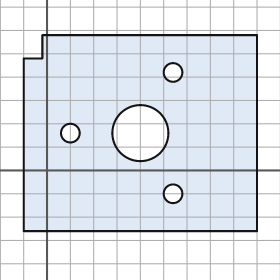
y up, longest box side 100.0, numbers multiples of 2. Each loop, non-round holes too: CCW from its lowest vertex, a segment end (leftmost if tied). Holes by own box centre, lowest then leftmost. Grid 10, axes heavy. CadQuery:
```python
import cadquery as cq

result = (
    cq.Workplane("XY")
    .moveTo(-10.0, -26.0)
    .lineTo(90.0, -26.0)
    .lineTo(90.0, 58.0)
    .lineTo(-2.0, 58.0)
    .lineTo(-2.0, 48.0)
    .lineTo(-10.0, 48.0)
    .close()
    .moveTo(54.0, -10.0)
    .circle(4.0)
    .moveTo(10.0, 16.0)
    .circle(4.0)
    .moveTo(40.0, 16.0)
    .circle(12.0)
    .moveTo(54.0, 42.0)
    .circle(4.0)
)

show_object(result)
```